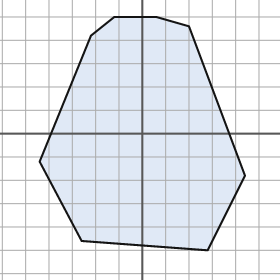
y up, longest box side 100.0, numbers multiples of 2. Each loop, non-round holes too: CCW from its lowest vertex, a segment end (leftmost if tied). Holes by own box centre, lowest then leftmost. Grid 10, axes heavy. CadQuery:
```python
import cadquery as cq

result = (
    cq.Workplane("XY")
    .moveTo(28.0, -50.0)
    .lineTo(44.0, -18.0)
    .lineTo(20.0, 46.0)
    .lineTo(6.0, 50.0)
    .lineTo(-12.0, 50.0)
    .lineTo(-22.0, 42.0)
    .lineTo(-44.0, -12.0)
    .lineTo(-26.0, -46.0)
    .close()
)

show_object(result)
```